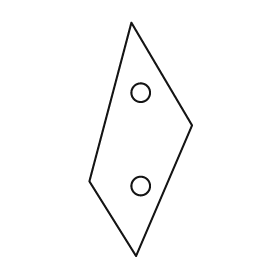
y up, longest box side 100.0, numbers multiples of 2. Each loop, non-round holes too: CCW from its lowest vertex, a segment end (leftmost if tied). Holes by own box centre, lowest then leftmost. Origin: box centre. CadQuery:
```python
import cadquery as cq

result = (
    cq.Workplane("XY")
    .moveTo(-2.0, -50.0)
    .lineTo(22.0, 6.0)
    .lineTo(-4.0, 50.0)
    .lineTo(-22.0, -18.0)
    .close()
    .moveTo(0.0, -20.0)
    .circle(4.0)
    .moveTo(0.0, 20.0)
    .circle(4.0)
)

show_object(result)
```